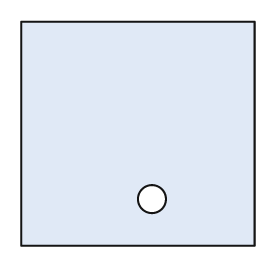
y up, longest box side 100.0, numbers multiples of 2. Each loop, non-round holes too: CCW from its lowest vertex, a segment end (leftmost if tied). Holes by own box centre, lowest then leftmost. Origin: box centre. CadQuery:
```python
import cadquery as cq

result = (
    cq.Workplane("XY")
    .moveTo(-50.0, -48.0)
    .lineTo(50.0, -48.0)
    .lineTo(50.0, 48.0)
    .lineTo(-50.0, 48.0)
    .close()
    .moveTo(6.0, -28.0)
    .circle(6.0)
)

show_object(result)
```